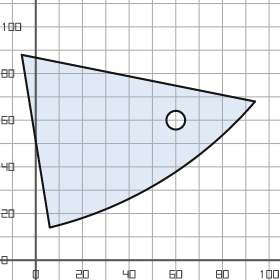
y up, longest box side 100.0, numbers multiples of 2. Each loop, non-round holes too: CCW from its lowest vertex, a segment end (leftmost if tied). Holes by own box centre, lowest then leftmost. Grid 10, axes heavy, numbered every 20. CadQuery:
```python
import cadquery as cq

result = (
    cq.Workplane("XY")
    .moveTo(6.0, 14.0)
    .threePointArc((54.0, 34.0), (94.0, 68.0))
    .lineTo(-6.0, 88.0)
    .close()
    .moveTo(60.0, 60.0)
    .circle(4.0)
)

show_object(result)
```